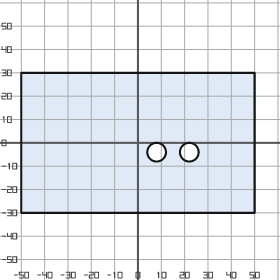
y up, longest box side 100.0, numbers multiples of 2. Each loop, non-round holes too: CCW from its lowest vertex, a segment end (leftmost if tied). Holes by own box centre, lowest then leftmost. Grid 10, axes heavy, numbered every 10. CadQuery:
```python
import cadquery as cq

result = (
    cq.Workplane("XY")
    .moveTo(-50.0, -30.0)
    .lineTo(50.0, -30.0)
    .lineTo(50.0, 30.0)
    .lineTo(-50.0, 30.0)
    .close()
    .moveTo(8.0, -4.0)
    .circle(4.0)
    .moveTo(22.0, -4.0)
    .circle(4.0)
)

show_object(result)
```